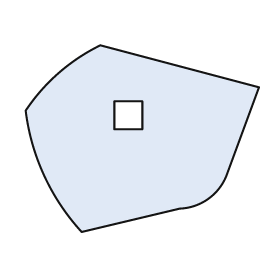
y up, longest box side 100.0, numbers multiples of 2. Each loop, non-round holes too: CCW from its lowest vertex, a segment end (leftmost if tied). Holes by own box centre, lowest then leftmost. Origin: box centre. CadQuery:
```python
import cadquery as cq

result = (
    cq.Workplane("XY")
    .moveTo(-26.0, -40.0)
    .lineTo(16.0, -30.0)
    .threePointArc((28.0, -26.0), (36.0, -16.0))
    .lineTo(50.0, 22.0)
    .lineTo(-18.0, 40.0)
    .threePointArc((-36.0, 28.0), (-50.0, 12.0))
    .threePointArc((-42.0, -16.0), (-26.0, -40.0))
    .close()
    .moveTo(-12.0, 4.0)
    .lineTo(0.0, 4.0)
    .lineTo(0.0, 16.0)
    .lineTo(-12.0, 16.0)
    .close()
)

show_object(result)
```